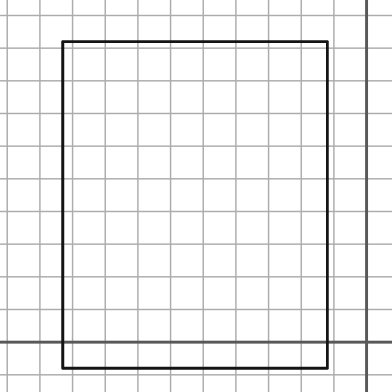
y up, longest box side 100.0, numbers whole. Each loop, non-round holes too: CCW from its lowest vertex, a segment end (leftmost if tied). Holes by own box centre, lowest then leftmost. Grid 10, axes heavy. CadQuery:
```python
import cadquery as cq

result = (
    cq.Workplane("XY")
    .moveTo(-93.0, -8.0)
    .lineTo(-12.0, -8.0)
    .lineTo(-12.0, 92.0)
    .lineTo(-93.0, 92.0)
    .close()
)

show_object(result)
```